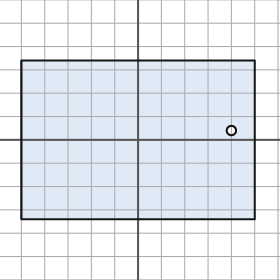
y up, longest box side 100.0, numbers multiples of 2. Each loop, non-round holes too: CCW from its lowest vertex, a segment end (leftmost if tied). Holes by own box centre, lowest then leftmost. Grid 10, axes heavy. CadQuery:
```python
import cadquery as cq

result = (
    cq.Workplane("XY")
    .moveTo(-50.0, -34.0)
    .lineTo(50.0, -34.0)
    .lineTo(50.0, 34.0)
    .lineTo(-50.0, 34.0)
    .close()
    .moveTo(40.0, 4.0)
    .circle(2.0)
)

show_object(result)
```